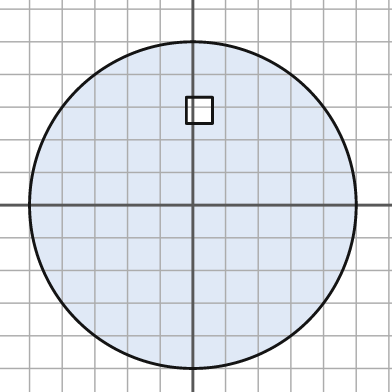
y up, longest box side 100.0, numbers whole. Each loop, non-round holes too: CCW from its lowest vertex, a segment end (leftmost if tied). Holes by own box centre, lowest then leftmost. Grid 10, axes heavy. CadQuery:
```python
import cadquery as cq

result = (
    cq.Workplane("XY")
    .moveTo(0.0, 0.0)
    .circle(50.0)
    .moveTo(-2.0, 25.0)
    .lineTo(6.0, 25.0)
    .lineTo(6.0, 33.0)
    .lineTo(-2.0, 33.0)
    .close()
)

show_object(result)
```